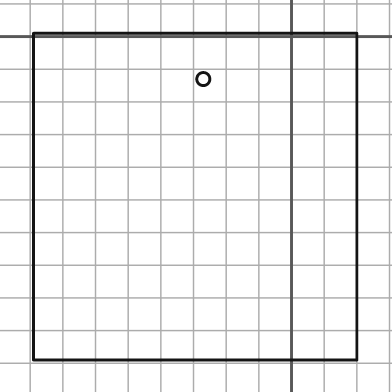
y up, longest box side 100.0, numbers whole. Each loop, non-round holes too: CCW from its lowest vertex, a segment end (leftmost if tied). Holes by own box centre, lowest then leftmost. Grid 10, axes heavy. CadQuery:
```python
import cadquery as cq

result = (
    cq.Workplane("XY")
    .moveTo(-79.0, -99.0)
    .lineTo(20.0, -99.0)
    .lineTo(20.0, 1.0)
    .lineTo(-79.0, 1.0)
    .close()
    .moveTo(-27.0, -13.0)
    .circle(2.0)
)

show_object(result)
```